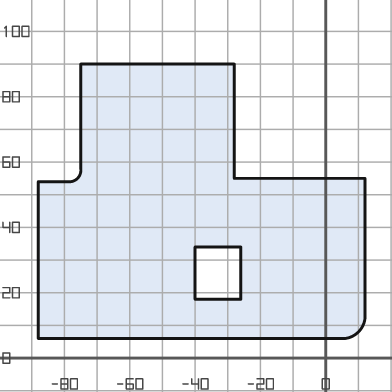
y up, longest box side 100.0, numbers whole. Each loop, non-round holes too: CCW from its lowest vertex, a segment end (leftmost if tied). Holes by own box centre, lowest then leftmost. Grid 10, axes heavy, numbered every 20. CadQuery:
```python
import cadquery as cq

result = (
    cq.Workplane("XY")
    .moveTo(-88.0, 6.0)
    .lineTo(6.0, 6.0)
    .threePointArc((10.0, 8.0), (12.0, 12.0))
    .lineTo(12.0, 55.0)
    .lineTo(-28.0, 55.0)
    .lineTo(-28.0, 90.0)
    .lineTo(-75.0, 90.0)
    .lineTo(-75.0, 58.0)
    .threePointArc((-76.0, 55.0), (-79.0, 54.0))
    .lineTo(-88.0, 54.0)
    .close()
    .moveTo(-40.0, 18.0)
    .lineTo(-26.0, 18.0)
    .lineTo(-26.0, 34.0)
    .lineTo(-40.0, 34.0)
    .close()
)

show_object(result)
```